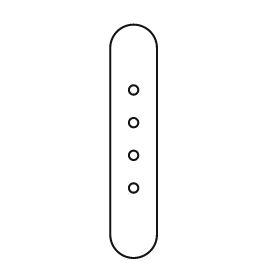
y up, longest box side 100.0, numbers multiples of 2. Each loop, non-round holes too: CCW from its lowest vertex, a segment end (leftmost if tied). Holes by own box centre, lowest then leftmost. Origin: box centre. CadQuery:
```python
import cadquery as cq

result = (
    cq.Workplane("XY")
    .moveTo(-10.0, -40.0)
    .threePointArc((0.0, -50.0), (10.0, -40.0))
    .lineTo(10.0, 40.0)
    .threePointArc((0.0, 50.0), (-10.0, 40.0))
    .close()
    .moveTo(0.0, -20.0)
    .circle(2.0)
    .moveTo(0.0, -6.0)
    .circle(2.0)
    .moveTo(0.0, 8.0)
    .circle(2.0)
    .moveTo(0.0, 22.0)
    .circle(2.0)
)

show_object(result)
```